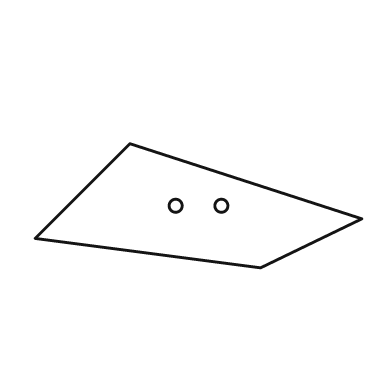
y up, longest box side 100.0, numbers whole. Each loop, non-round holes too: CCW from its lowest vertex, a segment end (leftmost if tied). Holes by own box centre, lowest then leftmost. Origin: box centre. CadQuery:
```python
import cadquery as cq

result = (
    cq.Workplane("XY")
    .moveTo(19.0, -19.0)
    .lineTo(50.0, -4.0)
    .lineTo(-21.0, 19.0)
    .lineTo(-50.0, -10.0)
    .close()
    .moveTo(-7.0, 0.0)
    .circle(2.0)
    .moveTo(7.0, 0.0)
    .circle(2.0)
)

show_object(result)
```